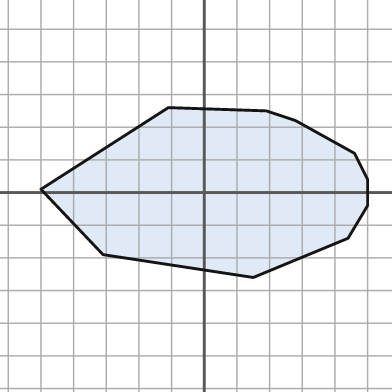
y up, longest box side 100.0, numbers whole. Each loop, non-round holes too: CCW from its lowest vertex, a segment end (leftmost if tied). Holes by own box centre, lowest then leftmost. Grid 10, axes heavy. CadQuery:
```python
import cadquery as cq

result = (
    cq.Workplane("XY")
    .moveTo(15.0, -26.0)
    .lineTo(44.0, -14.0)
    .lineTo(50.0, -4.0)
    .lineTo(50.0, 4.0)
    .lineTo(46.0, 12.0)
    .lineTo(28.0, 22.0)
    .lineTo(19.0, 25.0)
    .lineTo(-11.0, 26.0)
    .lineTo(-50.0, 1.0)
    .lineTo(-31.0, -19.0)
    .close()
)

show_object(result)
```